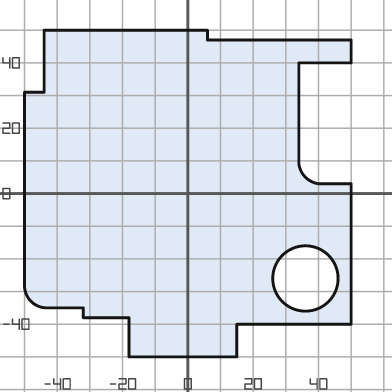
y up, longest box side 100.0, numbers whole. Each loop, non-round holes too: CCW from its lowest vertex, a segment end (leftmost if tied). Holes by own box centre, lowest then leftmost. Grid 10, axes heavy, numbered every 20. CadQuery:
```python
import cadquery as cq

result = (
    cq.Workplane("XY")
    .moveTo(-18.0, -50.0)
    .lineTo(15.0, -50.0)
    .lineTo(15.0, -40.0)
    .lineTo(50.0, -40.0)
    .lineTo(50.0, 3.0)
    .lineTo(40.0, 3.0)
    .threePointArc((36.0, 5.0), (34.0, 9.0))
    .lineTo(34.0, 40.0)
    .lineTo(50.0, 40.0)
    .lineTo(50.0, 47.0)
    .lineTo(6.0, 47.0)
    .lineTo(6.0, 50.0)
    .lineTo(-44.0, 50.0)
    .lineTo(-44.0, 31.0)
    .lineTo(-50.0, 31.0)
    .lineTo(-50.0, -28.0)
    .threePointArc((-48.0, -33.0), (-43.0, -35.0))
    .lineTo(-32.0, -35.0)
    .lineTo(-32.0, -38.0)
    .lineTo(-18.0, -38.0)
    .close()
    .moveTo(36.0, -26.0)
    .circle(10.0)
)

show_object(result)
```